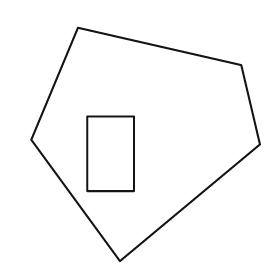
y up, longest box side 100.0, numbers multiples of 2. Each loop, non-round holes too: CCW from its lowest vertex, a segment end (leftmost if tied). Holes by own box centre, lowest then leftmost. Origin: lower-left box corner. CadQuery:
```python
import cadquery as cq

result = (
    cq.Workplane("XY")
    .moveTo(38.0, 0.0)
    .lineTo(98.0, 50.0)
    .lineTo(90.0, 84.0)
    .lineTo(20.0, 100.0)
    .lineTo(0.0, 52.0)
    .close()
    .moveTo(24.0, 30.0)
    .lineTo(44.0, 30.0)
    .lineTo(44.0, 62.0)
    .lineTo(24.0, 62.0)
    .close()
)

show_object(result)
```